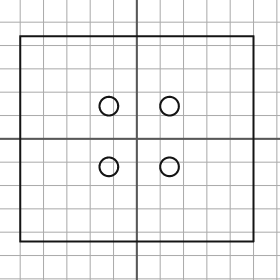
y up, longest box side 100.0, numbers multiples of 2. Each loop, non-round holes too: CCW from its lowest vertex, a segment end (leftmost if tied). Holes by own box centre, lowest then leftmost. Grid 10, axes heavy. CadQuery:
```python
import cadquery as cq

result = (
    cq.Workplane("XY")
    .moveTo(-50.0, -44.0)
    .lineTo(50.0, -44.0)
    .lineTo(50.0, 44.0)
    .lineTo(-50.0, 44.0)
    .close()
    .moveTo(-12.0, -12.0)
    .circle(4.0)
    .moveTo(14.0, -12.0)
    .circle(4.0)
    .moveTo(-12.0, 14.0)
    .circle(4.0)
    .moveTo(14.0, 14.0)
    .circle(4.0)
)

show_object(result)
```